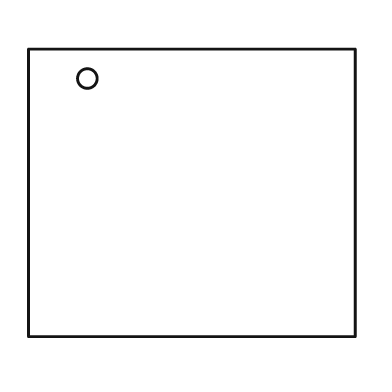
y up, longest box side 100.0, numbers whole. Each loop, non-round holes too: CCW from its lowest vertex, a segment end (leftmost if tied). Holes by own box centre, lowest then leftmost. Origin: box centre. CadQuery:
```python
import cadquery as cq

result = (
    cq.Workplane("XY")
    .moveTo(-50.0, -44.0)
    .lineTo(50.0, -44.0)
    .lineTo(50.0, 44.0)
    .lineTo(-50.0, 44.0)
    .close()
    .moveTo(-32.0, 35.0)
    .circle(3.0)
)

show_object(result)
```